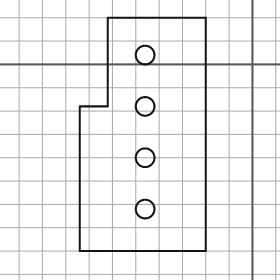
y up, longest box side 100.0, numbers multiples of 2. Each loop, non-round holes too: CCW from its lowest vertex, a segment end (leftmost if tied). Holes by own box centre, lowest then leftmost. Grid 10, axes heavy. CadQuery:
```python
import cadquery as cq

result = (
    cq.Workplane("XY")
    .moveTo(-74.0, -80.0)
    .lineTo(-20.0, -80.0)
    .lineTo(-20.0, 20.0)
    .lineTo(-62.0, 20.0)
    .lineTo(-62.0, -18.0)
    .lineTo(-74.0, -18.0)
    .close()
    .moveTo(-46.0, -62.0)
    .circle(4.0)
    .moveTo(-46.0, -40.0)
    .circle(4.0)
    .moveTo(-46.0, -18.0)
    .circle(4.0)
    .moveTo(-46.0, 4.0)
    .circle(4.0)
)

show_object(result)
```